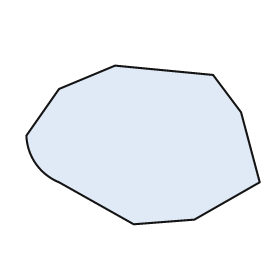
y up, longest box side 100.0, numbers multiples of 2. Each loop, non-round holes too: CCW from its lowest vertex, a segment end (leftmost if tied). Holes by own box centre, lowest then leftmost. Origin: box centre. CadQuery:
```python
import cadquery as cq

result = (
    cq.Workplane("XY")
    .moveTo(-4.0, -34.0)
    .lineTo(22.0, -32.0)
    .lineTo(50.0, -16.0)
    .lineTo(42.0, 14.0)
    .lineTo(30.0, 30.0)
    .lineTo(-12.0, 34.0)
    .lineTo(-36.0, 24.0)
    .lineTo(-50.0, 4.0)
    .threePointArc((-46.0, -8.0), (-36.0, -16.0))
    .close()
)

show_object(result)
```